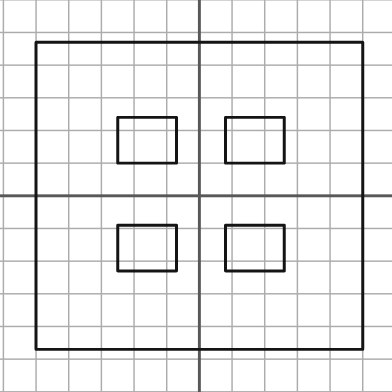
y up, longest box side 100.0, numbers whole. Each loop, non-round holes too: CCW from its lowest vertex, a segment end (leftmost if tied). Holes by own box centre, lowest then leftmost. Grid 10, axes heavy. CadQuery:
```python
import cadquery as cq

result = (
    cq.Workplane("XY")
    .moveTo(-50.0, -47.0)
    .lineTo(50.0, -47.0)
    .lineTo(50.0, 47.0)
    .lineTo(-50.0, 47.0)
    .close()
    .moveTo(-25.0, -23.0)
    .lineTo(-7.0, -23.0)
    .lineTo(-7.0, -9.0)
    .lineTo(-25.0, -9.0)
    .close()
    .moveTo(8.0, -23.0)
    .lineTo(26.0, -23.0)
    .lineTo(26.0, -9.0)
    .lineTo(8.0, -9.0)
    .close()
    .moveTo(-25.0, 10.0)
    .lineTo(-7.0, 10.0)
    .lineTo(-7.0, 24.0)
    .lineTo(-25.0, 24.0)
    .close()
    .moveTo(8.0, 10.0)
    .lineTo(26.0, 10.0)
    .lineTo(26.0, 24.0)
    .lineTo(8.0, 24.0)
    .close()
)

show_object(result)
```